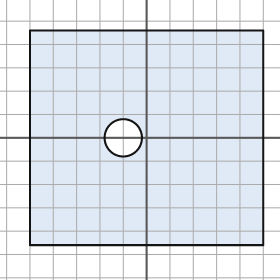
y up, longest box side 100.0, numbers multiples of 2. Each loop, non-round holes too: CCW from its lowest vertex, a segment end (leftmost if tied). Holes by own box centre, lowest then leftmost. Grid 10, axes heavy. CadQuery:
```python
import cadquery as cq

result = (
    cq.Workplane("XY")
    .moveTo(-50.0, -46.0)
    .lineTo(50.0, -46.0)
    .lineTo(50.0, 46.0)
    .lineTo(-50.0, 46.0)
    .close()
    .moveTo(-10.0, 0.0)
    .circle(8.0)
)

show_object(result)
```